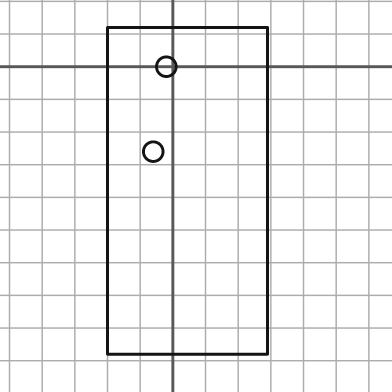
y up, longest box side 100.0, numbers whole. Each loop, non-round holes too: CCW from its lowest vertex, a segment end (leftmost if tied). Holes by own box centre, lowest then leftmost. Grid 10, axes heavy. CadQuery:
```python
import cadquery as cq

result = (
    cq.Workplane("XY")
    .moveTo(-20.0, -88.0)
    .lineTo(29.0, -88.0)
    .lineTo(29.0, 12.0)
    .lineTo(-20.0, 12.0)
    .close()
    .moveTo(-6.0, -26.0)
    .circle(3.0)
    .moveTo(-2.0, 0.0)
    .circle(3.0)
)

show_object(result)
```